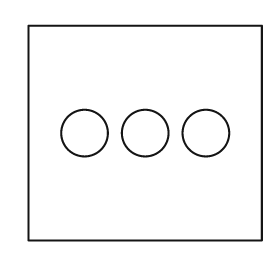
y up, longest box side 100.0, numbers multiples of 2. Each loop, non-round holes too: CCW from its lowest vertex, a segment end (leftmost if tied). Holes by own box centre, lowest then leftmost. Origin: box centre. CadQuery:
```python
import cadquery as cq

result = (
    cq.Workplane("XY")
    .moveTo(-50.0, -46.0)
    .lineTo(50.0, -46.0)
    .lineTo(50.0, 46.0)
    .lineTo(-50.0, 46.0)
    .close()
    .moveTo(-26.0, 0.0)
    .circle(10.0)
    .moveTo(0.0, 0.0)
    .circle(10.0)
    .moveTo(26.0, 0.0)
    .circle(10.0)
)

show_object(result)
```